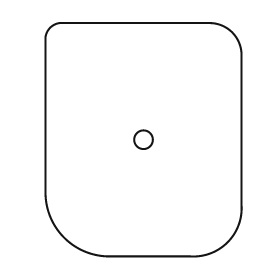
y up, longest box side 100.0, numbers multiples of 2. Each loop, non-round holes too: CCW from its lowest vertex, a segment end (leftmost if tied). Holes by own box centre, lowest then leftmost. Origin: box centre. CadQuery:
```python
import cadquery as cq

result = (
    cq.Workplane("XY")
    .moveTo(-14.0, -50.0)
    .lineTo(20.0, -50.0)
    .threePointArc((36.0, -44.0), (42.0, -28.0))
    .lineTo(42.0, 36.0)
    .threePointArc((38.0, 46.0), (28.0, 50.0))
    .lineTo(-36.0, 50.0)
    .threePointArc((-40.0, 48.0), (-42.0, 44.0))
    .lineTo(-42.0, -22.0)
    .threePointArc((-34.0, -42.0), (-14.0, -50.0))
    .close()
    .moveTo(0.0, 0.0)
    .circle(4.0)
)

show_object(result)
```